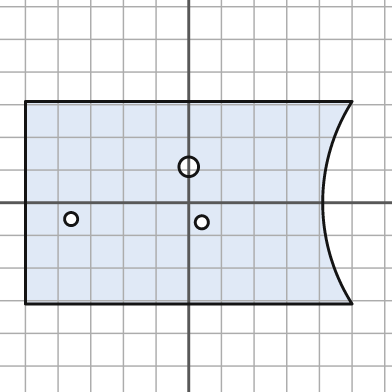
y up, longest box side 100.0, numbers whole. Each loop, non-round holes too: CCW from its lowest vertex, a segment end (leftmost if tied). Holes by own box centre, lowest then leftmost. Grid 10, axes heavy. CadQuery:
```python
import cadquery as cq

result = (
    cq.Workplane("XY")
    .moveTo(-50.0, -31.0)
    .lineTo(50.0, -31.0)
    .threePointArc((41.0, 0.0), (50.0, 31.0))
    .lineTo(-50.0, 31.0)
    .close()
    .moveTo(4.0, -6.0)
    .circle(2.0)
    .moveTo(-36.0, -5.0)
    .circle(2.0)
    .moveTo(0.0, 11.0)
    .circle(3.0)
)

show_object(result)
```